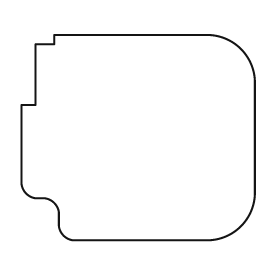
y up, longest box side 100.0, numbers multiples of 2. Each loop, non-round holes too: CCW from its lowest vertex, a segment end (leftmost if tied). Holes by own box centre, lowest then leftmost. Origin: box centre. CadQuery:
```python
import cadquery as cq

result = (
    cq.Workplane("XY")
    .moveTo(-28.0, -44.0)
    .lineTo(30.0, -44.0)
    .threePointArc((44.0, -38.0), (50.0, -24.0))
    .lineTo(50.0, 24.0)
    .threePointArc((44.0, 38.0), (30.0, 44.0))
    .lineTo(-36.0, 44.0)
    .lineTo(-36.0, 40.0)
    .lineTo(-44.0, 40.0)
    .lineTo(-44.0, 14.0)
    .lineTo(-50.0, 14.0)
    .lineTo(-50.0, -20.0)
    .threePointArc((-48.0, -24.0), (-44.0, -26.0))
    .lineTo(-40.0, -26.0)
    .threePointArc((-36.0, -28.0), (-34.0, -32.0))
    .lineTo(-34.0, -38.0)
    .threePointArc((-32.0, -42.0), (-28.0, -44.0))
    .close()
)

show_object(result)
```